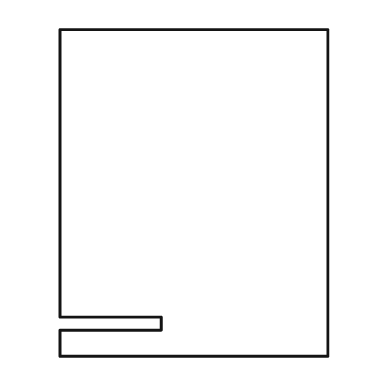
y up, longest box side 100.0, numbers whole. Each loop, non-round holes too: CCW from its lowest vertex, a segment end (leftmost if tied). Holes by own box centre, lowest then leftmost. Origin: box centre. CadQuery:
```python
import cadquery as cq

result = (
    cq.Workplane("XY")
    .moveTo(-41.0, -50.0)
    .lineTo(41.0, -50.0)
    .lineTo(41.0, 50.0)
    .lineTo(-41.0, 50.0)
    .lineTo(-41.0, -38.0)
    .lineTo(-10.0, -38.0)
    .lineTo(-10.0, -42.0)
    .lineTo(-41.0, -42.0)
    .close()
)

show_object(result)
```